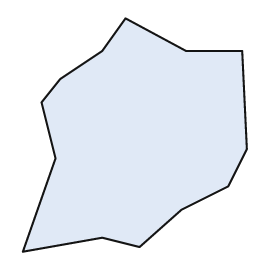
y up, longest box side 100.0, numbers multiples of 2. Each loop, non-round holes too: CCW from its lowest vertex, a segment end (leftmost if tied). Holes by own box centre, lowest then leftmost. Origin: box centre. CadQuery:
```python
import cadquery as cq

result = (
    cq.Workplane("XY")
    .moveTo(-48.0, -50.0)
    .lineTo(-14.0, -44.0)
    .lineTo(2.0, -48.0)
    .lineTo(20.0, -32.0)
    .lineTo(40.0, -22.0)
    .lineTo(48.0, -6.0)
    .lineTo(46.0, 36.0)
    .lineTo(22.0, 36.0)
    .lineTo(-4.0, 50.0)
    .lineTo(-14.0, 36.0)
    .lineTo(-32.0, 24.0)
    .lineTo(-40.0, 14.0)
    .lineTo(-34.0, -10.0)
    .close()
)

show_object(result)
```